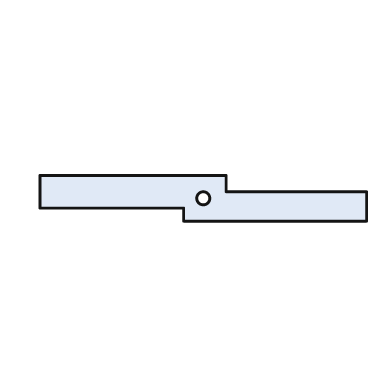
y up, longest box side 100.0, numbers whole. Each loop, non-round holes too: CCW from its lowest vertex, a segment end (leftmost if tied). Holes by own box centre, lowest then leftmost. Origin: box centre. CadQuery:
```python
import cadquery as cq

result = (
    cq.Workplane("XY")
    .moveTo(-6.0, -7.0)
    .lineTo(50.0, -7.0)
    .lineTo(50.0, 2.0)
    .lineTo(7.0, 2.0)
    .lineTo(7.0, 7.0)
    .lineTo(-50.0, 7.0)
    .lineTo(-50.0, -3.0)
    .lineTo(-6.0, -3.0)
    .close()
    .moveTo(0.0, 0.0)
    .circle(2.0)
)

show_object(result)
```